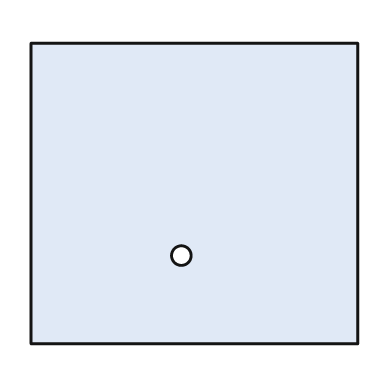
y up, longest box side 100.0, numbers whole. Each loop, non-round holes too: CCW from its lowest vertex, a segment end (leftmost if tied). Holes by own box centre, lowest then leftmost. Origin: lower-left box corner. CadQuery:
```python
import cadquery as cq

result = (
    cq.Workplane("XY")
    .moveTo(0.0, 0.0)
    .lineTo(100.0, 0.0)
    .lineTo(100.0, 92.0)
    .lineTo(0.0, 92.0)
    .close()
    .moveTo(46.0, 27.0)
    .circle(3.0)
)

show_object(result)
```